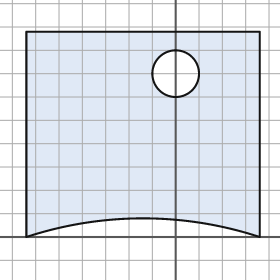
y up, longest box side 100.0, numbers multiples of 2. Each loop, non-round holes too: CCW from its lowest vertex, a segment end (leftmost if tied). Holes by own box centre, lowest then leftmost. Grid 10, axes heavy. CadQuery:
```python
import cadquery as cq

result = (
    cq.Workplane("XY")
    .moveTo(-64.0, 0.0)
    .threePointArc((-14.0, 8.0), (36.0, 0.0))
    .lineTo(36.0, 88.0)
    .lineTo(-64.0, 88.0)
    .close()
    .moveTo(0.0, 70.0)
    .circle(10.0)
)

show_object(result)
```